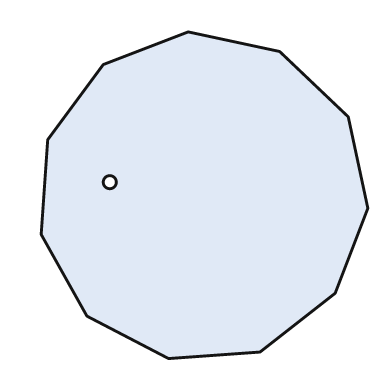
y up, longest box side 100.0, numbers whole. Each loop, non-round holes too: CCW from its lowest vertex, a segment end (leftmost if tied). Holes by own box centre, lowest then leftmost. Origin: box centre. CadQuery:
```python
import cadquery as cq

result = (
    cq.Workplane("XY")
    .moveTo(-11.0, -50.0)
    .lineTo(17.0, -48.0)
    .lineTo(40.0, -30.0)
    .lineTo(50.0, -4.0)
    .lineTo(44.0, 24.0)
    .lineTo(23.0, 44.0)
    .lineTo(-5.0, 50.0)
    .lineTo(-31.0, 40.0)
    .lineTo(-48.0, 17.0)
    .lineTo(-50.0, -12.0)
    .lineTo(-36.0, -37.0)
    .close()
    .moveTo(-29.0, 4.0)
    .circle(2.0)
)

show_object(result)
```